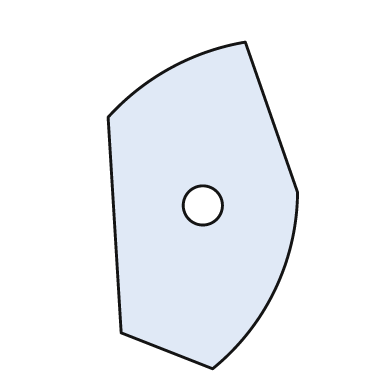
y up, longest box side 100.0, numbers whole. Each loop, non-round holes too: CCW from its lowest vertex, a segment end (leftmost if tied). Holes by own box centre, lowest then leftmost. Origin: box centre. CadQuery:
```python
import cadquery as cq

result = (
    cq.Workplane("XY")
    .moveTo(3.0, -50.0)
    .threePointArc((22.0, -26.0), (29.0, 4.0))
    .lineTo(13.0, 50.0)
    .threePointArc((-10.0, 42.0), (-29.0, 27.0))
    .lineTo(-25.0, -39.0)
    .close()
    .moveTo(0.0, 0.0)
    .circle(6.0)
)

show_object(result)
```